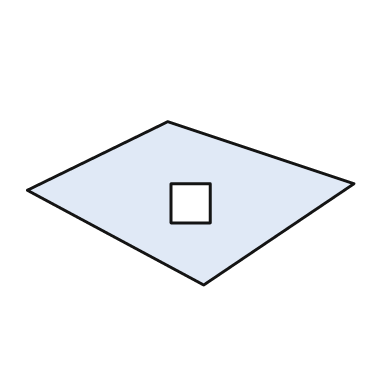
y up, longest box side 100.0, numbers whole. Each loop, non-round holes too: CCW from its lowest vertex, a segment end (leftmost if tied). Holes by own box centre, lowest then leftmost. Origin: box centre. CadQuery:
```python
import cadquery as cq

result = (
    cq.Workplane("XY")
    .moveTo(4.0, -25.0)
    .lineTo(50.0, 6.0)
    .lineTo(-7.0, 25.0)
    .lineTo(-50.0, 4.0)
    .close()
    .moveTo(-6.0, -6.0)
    .lineTo(6.0, -6.0)
    .lineTo(6.0, 6.0)
    .lineTo(-6.0, 6.0)
    .close()
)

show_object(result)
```